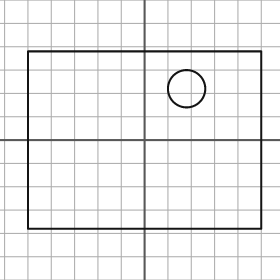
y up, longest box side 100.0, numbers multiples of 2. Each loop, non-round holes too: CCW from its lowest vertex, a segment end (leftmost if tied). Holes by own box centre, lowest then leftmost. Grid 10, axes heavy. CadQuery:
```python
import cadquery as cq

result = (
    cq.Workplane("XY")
    .moveTo(-50.0, -38.0)
    .lineTo(50.0, -38.0)
    .lineTo(50.0, 38.0)
    .lineTo(-50.0, 38.0)
    .close()
    .moveTo(18.0, 22.0)
    .circle(8.0)
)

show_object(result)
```